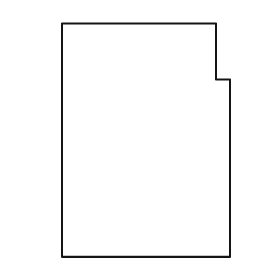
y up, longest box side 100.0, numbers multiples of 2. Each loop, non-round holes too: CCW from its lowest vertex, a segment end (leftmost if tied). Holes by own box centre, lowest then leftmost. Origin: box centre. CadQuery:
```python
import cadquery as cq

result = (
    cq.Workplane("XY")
    .moveTo(-36.0, -50.0)
    .lineTo(36.0, -50.0)
    .lineTo(36.0, 26.0)
    .lineTo(30.0, 26.0)
    .lineTo(30.0, 50.0)
    .lineTo(-36.0, 50.0)
    .close()
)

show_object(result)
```